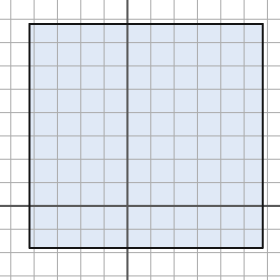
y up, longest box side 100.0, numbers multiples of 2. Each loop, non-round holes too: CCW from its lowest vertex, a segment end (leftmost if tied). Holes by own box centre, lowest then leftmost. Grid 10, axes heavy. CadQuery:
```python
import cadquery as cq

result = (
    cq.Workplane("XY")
    .moveTo(-42.0, -18.0)
    .lineTo(58.0, -18.0)
    .lineTo(58.0, 78.0)
    .lineTo(-42.0, 78.0)
    .close()
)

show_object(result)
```